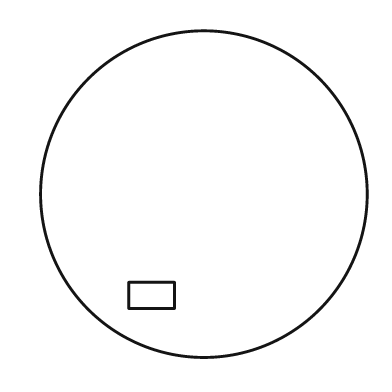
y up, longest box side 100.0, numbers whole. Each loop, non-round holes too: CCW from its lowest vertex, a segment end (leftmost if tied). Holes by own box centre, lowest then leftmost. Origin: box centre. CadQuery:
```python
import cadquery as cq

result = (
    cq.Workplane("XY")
    .moveTo(0.0, 0.0)
    .circle(50.0)
    .moveTo(-23.0, -35.0)
    .lineTo(-9.0, -35.0)
    .lineTo(-9.0, -27.0)
    .lineTo(-23.0, -27.0)
    .close()
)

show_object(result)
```